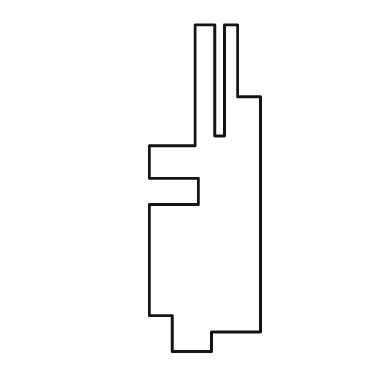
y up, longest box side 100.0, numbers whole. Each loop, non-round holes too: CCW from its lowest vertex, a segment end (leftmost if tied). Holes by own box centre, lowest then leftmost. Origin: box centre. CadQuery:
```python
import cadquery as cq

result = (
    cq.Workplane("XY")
    .moveTo(-10.0, -50.0)
    .lineTo(2.0, -50.0)
    .lineTo(2.0, -44.0)
    .lineTo(17.0, -44.0)
    .lineTo(17.0, 28.0)
    .lineTo(10.0, 28.0)
    .lineTo(10.0, 50.0)
    .lineTo(6.0, 50.0)
    .lineTo(6.0, 16.0)
    .lineTo(3.0, 16.0)
    .lineTo(3.0, 50.0)
    .lineTo(-3.0, 50.0)
    .lineTo(-3.0, 13.0)
    .lineTo(-17.0, 13.0)
    .lineTo(-17.0, 3.0)
    .lineTo(-2.0, 3.0)
    .lineTo(-2.0, -5.0)
    .lineTo(-17.0, -5.0)
    .lineTo(-17.0, -39.0)
    .lineTo(-10.0, -39.0)
    .close()
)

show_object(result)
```